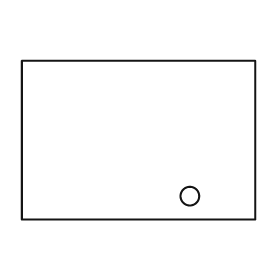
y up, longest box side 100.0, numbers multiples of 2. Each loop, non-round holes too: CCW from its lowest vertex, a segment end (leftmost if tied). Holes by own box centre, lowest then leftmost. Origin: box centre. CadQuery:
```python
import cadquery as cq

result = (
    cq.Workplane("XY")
    .moveTo(-50.0, -34.0)
    .lineTo(50.0, -34.0)
    .lineTo(50.0, 34.0)
    .lineTo(-50.0, 34.0)
    .close()
    .moveTo(22.0, -24.0)
    .circle(4.0)
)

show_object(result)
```